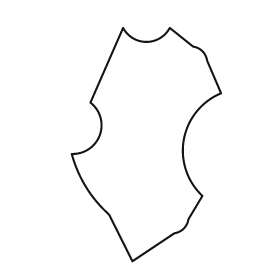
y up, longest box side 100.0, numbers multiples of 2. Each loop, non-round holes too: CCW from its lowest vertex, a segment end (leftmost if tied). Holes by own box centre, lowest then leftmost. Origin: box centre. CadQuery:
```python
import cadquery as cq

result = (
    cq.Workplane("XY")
    .moveTo(-6.0, -50.0)
    .lineTo(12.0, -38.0)
    .threePointArc((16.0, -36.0), (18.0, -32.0))
    .lineTo(24.0, -22.0)
    .threePointArc((16.0, 2.0), (32.0, 22.0))
    .lineTo(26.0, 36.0)
    .threePointArc((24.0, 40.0), (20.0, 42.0))
    .lineTo(10.0, 50.0)
    .threePointArc((0.0, 44.0), (-10.0, 50.0))
    .lineTo(-24.0, 18.0)
    .threePointArc((-20.0, 4.0), (-32.0, -4.0))
    .threePointArc((-26.0, -18.0), (-16.0, -30.0))
    .close()
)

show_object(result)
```